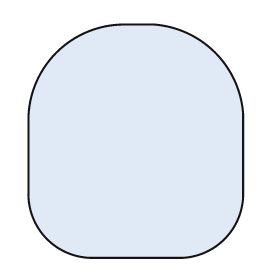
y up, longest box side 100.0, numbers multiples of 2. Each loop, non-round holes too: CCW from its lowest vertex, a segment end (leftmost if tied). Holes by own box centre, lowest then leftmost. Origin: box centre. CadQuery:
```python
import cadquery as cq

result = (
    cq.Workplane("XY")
    .moveTo(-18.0, -50.0)
    .lineTo(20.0, -50.0)
    .threePointArc((38.0, -42.0), (46.0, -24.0))
    .lineTo(46.0, 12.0)
    .threePointArc((34.0, 38.0), (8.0, 50.0))
    .lineTo(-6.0, 50.0)
    .threePointArc((-34.0, 38.0), (-46.0, 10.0))
    .lineTo(-46.0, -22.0)
    .threePointArc((-38.0, -42.0), (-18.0, -50.0))
    .close()
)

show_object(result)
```